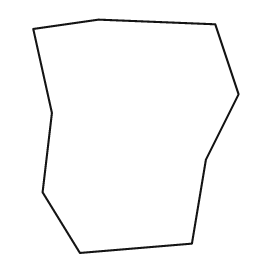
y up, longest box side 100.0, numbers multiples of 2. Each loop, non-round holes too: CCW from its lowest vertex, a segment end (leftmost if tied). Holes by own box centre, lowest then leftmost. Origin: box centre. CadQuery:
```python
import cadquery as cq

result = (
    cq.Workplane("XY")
    .moveTo(-24.0, -50.0)
    .lineTo(24.0, -46.0)
    .lineTo(30.0, -10.0)
    .lineTo(44.0, 18.0)
    .lineTo(34.0, 48.0)
    .lineTo(-16.0, 50.0)
    .lineTo(-44.0, 46.0)
    .lineTo(-36.0, 10.0)
    .lineTo(-40.0, -24.0)
    .close()
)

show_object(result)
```